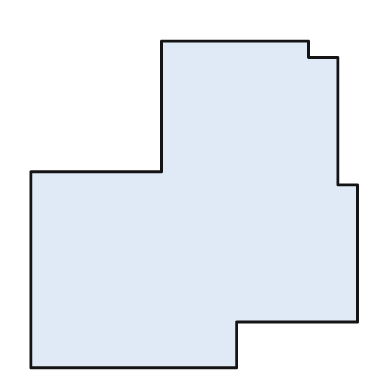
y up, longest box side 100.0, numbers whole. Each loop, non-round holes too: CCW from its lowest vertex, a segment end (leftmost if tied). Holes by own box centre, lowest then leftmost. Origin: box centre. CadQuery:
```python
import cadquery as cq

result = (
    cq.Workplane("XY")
    .moveTo(-50.0, -50.0)
    .lineTo(13.0, -50.0)
    .lineTo(13.0, -36.0)
    .lineTo(50.0, -36.0)
    .lineTo(50.0, 6.0)
    .lineTo(44.0, 6.0)
    .lineTo(44.0, 45.0)
    .lineTo(35.0, 45.0)
    .lineTo(35.0, 50.0)
    .lineTo(-10.0, 50.0)
    .lineTo(-10.0, 10.0)
    .lineTo(-50.0, 10.0)
    .close()
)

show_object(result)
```